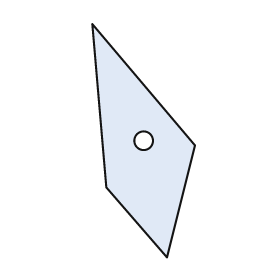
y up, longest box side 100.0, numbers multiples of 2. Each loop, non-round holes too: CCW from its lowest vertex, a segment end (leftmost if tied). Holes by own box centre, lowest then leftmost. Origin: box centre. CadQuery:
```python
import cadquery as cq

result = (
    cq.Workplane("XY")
    .moveTo(10.0, -50.0)
    .lineTo(22.0, -2.0)
    .lineTo(-22.0, 50.0)
    .lineTo(-16.0, -20.0)
    .close()
    .moveTo(0.0, 0.0)
    .circle(4.0)
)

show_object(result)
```